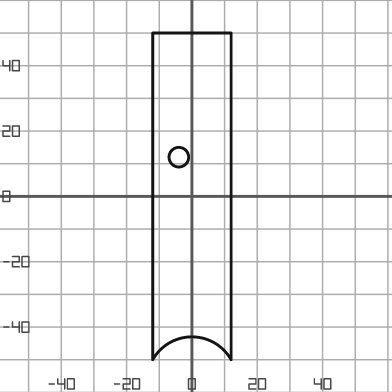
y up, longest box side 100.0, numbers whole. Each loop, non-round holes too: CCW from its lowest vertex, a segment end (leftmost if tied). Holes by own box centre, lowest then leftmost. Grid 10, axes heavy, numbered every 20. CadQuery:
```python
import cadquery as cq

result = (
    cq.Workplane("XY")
    .moveTo(-12.0, -50.0)
    .threePointArc((0.0, -43.0), (12.0, -50.0))
    .lineTo(12.0, 50.0)
    .lineTo(-12.0, 50.0)
    .close()
    .moveTo(-4.0, 12.0)
    .circle(3.0)
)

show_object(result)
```